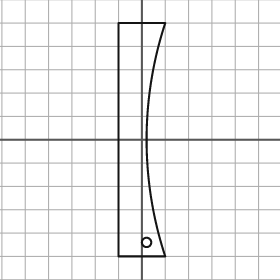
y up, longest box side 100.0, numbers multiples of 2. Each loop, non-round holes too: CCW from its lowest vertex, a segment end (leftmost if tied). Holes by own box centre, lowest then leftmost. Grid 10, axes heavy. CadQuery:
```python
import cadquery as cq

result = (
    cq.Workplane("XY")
    .moveTo(-10.0, -50.0)
    .lineTo(10.0, -50.0)
    .threePointArc((2.0, 0.0), (10.0, 50.0))
    .lineTo(-10.0, 50.0)
    .close()
    .moveTo(2.0, -44.0)
    .circle(2.0)
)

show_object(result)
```